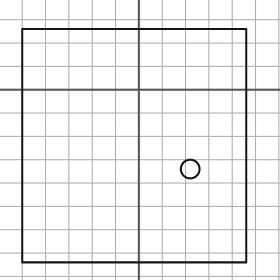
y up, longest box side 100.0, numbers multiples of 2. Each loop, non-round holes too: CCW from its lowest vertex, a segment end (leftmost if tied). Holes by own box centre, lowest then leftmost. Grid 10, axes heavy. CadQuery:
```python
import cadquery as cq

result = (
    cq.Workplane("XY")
    .moveTo(-50.0, -74.0)
    .lineTo(46.0, -74.0)
    .lineTo(46.0, 26.0)
    .lineTo(-50.0, 26.0)
    .close()
    .moveTo(22.0, -34.0)
    .circle(4.0)
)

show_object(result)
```